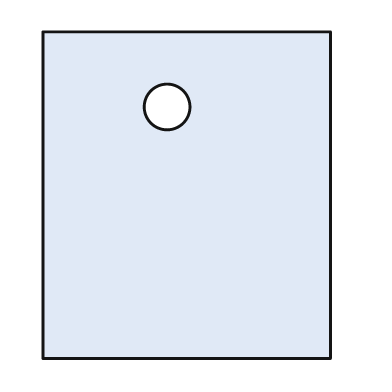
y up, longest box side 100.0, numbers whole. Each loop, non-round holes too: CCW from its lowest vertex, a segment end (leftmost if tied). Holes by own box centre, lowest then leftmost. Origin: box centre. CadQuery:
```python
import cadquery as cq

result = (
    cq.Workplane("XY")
    .moveTo(-44.0, -50.0)
    .lineTo(44.0, -50.0)
    .lineTo(44.0, 50.0)
    .lineTo(-44.0, 50.0)
    .close()
    .moveTo(-6.0, 27.0)
    .circle(7.0)
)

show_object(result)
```